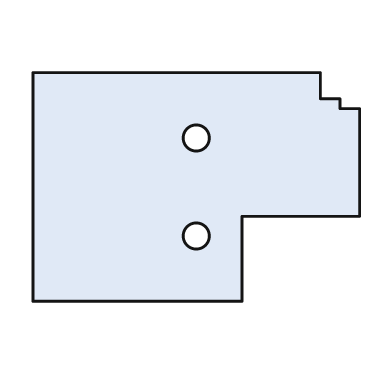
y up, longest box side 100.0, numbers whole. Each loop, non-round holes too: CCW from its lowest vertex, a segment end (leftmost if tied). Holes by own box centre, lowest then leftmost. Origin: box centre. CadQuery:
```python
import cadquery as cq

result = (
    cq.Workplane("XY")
    .moveTo(-50.0, -35.0)
    .lineTo(14.0, -35.0)
    .lineTo(14.0, -9.0)
    .lineTo(50.0, -9.0)
    .lineTo(50.0, 24.0)
    .lineTo(44.0, 24.0)
    .lineTo(44.0, 27.0)
    .lineTo(38.0, 27.0)
    .lineTo(38.0, 35.0)
    .lineTo(-50.0, 35.0)
    .close()
    .moveTo(0.0, -15.0)
    .circle(4.0)
    .moveTo(0.0, 15.0)
    .circle(4.0)
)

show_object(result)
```